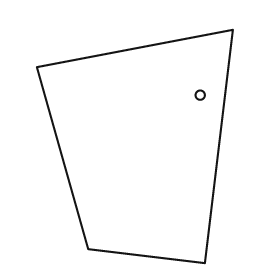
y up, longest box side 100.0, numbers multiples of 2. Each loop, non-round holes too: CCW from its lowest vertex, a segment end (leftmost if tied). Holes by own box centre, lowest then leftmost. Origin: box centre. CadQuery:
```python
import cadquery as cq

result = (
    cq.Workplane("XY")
    .moveTo(30.0, -50.0)
    .lineTo(42.0, 50.0)
    .lineTo(-42.0, 34.0)
    .lineTo(-20.0, -44.0)
    .close()
    .moveTo(28.0, 22.0)
    .circle(2.0)
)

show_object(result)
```